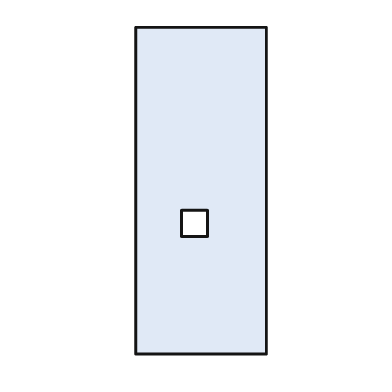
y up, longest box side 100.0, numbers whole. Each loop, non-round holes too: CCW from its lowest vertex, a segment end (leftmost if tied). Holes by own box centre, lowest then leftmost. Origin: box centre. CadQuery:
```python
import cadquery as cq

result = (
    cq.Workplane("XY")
    .moveTo(-20.0, -50.0)
    .lineTo(20.0, -50.0)
    .lineTo(20.0, 50.0)
    .lineTo(-20.0, 50.0)
    .close()
    .moveTo(-6.0, -14.0)
    .lineTo(2.0, -14.0)
    .lineTo(2.0, -6.0)
    .lineTo(-6.0, -6.0)
    .close()
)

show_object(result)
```